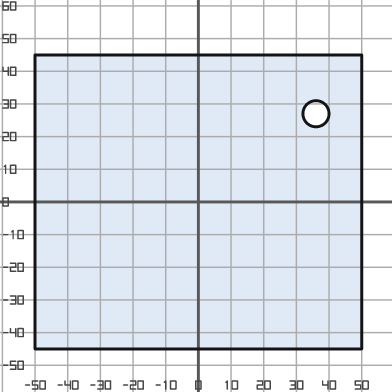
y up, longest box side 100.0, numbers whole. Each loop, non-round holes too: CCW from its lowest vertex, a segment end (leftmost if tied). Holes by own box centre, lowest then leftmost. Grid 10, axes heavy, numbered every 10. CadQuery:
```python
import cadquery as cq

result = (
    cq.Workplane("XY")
    .moveTo(-50.0, -45.0)
    .lineTo(50.0, -45.0)
    .lineTo(50.0, 45.0)
    .lineTo(-50.0, 45.0)
    .close()
    .moveTo(36.0, 27.0)
    .circle(4.0)
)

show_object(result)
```